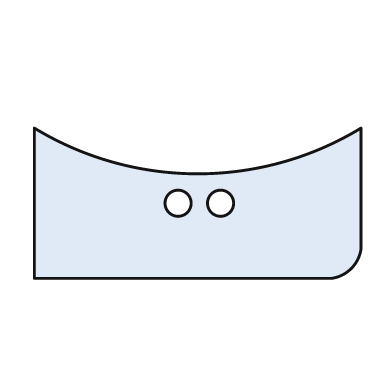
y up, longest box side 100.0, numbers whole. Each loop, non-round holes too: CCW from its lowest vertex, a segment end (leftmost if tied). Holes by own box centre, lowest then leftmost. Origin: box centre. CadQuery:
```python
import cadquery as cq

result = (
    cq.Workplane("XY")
    .moveTo(-50.0, -23.0)
    .lineTo(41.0, -23.0)
    .threePointArc((47.0, -20.0), (50.0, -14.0))
    .lineTo(50.0, 23.0)
    .threePointArc((0.0, 9.0), (-50.0, 23.0))
    .close()
    .moveTo(-6.0, 0.0)
    .circle(4.0)
    .moveTo(7.0, 0.0)
    .circle(4.0)
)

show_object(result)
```